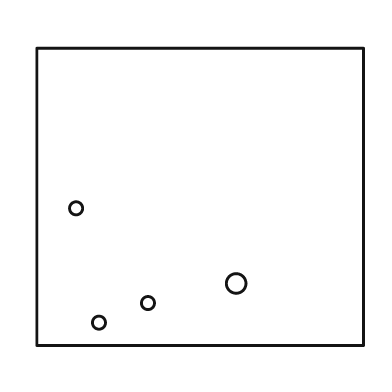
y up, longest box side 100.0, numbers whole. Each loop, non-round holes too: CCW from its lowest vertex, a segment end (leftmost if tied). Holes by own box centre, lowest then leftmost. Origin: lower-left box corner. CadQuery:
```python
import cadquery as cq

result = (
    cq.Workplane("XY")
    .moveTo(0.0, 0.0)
    .lineTo(100.0, 0.0)
    .lineTo(100.0, 91.0)
    .lineTo(0.0, 91.0)
    .close()
    .moveTo(19.0, 7.0)
    .circle(2.0)
    .moveTo(34.0, 13.0)
    .circle(2.0)
    .moveTo(61.0, 19.0)
    .circle(3.0)
    .moveTo(12.0, 42.0)
    .circle(2.0)
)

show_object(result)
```